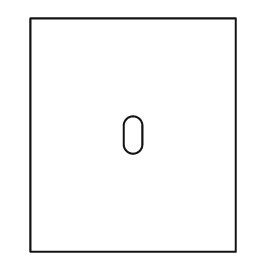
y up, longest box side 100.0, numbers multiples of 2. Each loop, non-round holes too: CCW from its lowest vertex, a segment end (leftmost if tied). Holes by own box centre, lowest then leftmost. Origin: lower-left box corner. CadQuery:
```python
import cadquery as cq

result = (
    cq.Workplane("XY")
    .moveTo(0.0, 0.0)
    .lineTo(88.0, 0.0)
    .lineTo(88.0, 100.0)
    .lineTo(0.0, 100.0)
    .close()
    .moveTo(40.0, 46.0)
    .threePointArc((44.0, 42.0), (48.0, 46.0))
    .lineTo(48.0, 54.0)
    .threePointArc((44.0, 58.0), (40.0, 54.0))
    .close()
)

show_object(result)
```